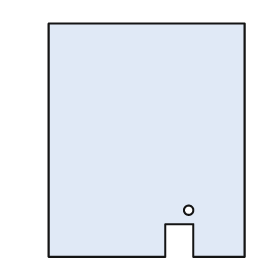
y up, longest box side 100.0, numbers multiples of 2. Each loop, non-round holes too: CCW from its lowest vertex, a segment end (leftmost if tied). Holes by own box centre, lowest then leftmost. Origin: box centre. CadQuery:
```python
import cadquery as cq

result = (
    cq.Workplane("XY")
    .moveTo(-42.0, -50.0)
    .lineTo(8.0, -50.0)
    .lineTo(8.0, -36.0)
    .lineTo(20.0, -36.0)
    .lineTo(20.0, -50.0)
    .lineTo(42.0, -50.0)
    .lineTo(42.0, 50.0)
    .lineTo(-42.0, 50.0)
    .close()
    .moveTo(18.0, -30.0)
    .circle(2.0)
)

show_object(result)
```